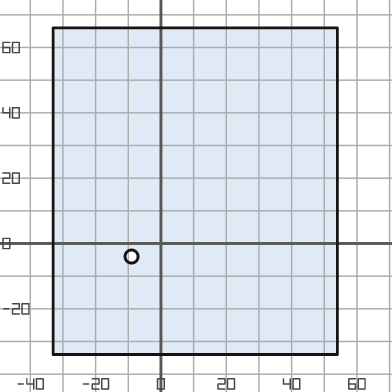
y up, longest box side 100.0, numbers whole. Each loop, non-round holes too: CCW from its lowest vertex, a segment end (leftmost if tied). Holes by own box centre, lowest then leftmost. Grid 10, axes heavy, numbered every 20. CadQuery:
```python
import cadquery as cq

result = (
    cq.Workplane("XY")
    .moveTo(-33.0, -34.0)
    .lineTo(54.0, -34.0)
    .lineTo(54.0, 66.0)
    .lineTo(-33.0, 66.0)
    .close()
    .moveTo(-9.0, -4.0)
    .circle(2.0)
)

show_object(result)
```